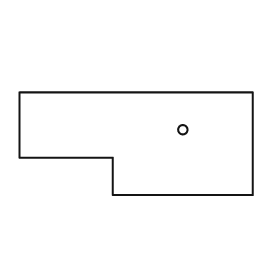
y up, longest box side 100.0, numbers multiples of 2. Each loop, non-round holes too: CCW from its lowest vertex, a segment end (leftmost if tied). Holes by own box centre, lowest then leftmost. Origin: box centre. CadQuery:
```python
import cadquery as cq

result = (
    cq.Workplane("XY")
    .moveTo(-10.0, -22.0)
    .lineTo(50.0, -22.0)
    .lineTo(50.0, 22.0)
    .lineTo(-50.0, 22.0)
    .lineTo(-50.0, -6.0)
    .lineTo(-10.0, -6.0)
    .close()
    .moveTo(20.0, 6.0)
    .circle(2.0)
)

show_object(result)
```